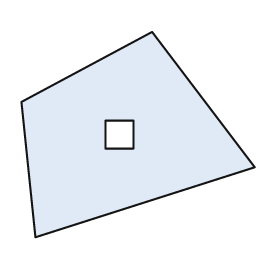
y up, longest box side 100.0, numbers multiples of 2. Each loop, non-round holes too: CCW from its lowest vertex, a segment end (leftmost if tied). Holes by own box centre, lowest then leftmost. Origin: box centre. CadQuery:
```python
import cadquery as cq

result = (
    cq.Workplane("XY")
    .moveTo(-44.0, -44.0)
    .lineTo(50.0, -14.0)
    .lineTo(6.0, 44.0)
    .lineTo(-50.0, 14.0)
    .close()
    .moveTo(-14.0, -6.0)
    .lineTo(-2.0, -6.0)
    .lineTo(-2.0, 6.0)
    .lineTo(-14.0, 6.0)
    .close()
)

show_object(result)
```